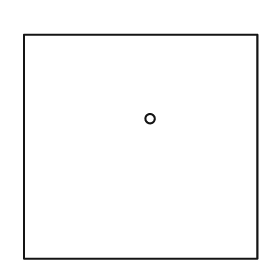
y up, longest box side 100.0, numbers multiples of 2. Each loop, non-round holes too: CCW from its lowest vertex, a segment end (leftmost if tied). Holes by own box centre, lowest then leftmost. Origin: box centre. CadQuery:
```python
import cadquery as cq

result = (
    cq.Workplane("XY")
    .moveTo(-50.0, -48.0)
    .lineTo(50.0, -48.0)
    .lineTo(50.0, 48.0)
    .lineTo(-50.0, 48.0)
    .close()
    .moveTo(4.0, 12.0)
    .circle(2.0)
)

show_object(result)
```